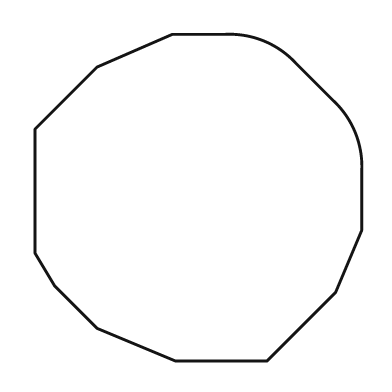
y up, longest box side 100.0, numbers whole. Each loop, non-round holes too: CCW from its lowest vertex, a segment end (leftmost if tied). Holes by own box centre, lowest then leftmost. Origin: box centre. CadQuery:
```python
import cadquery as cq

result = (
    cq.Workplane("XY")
    .moveTo(-7.0, -50.0)
    .lineTo(21.0, -50.0)
    .lineTo(42.0, -29.0)
    .lineTo(50.0, -10.0)
    .lineTo(50.0, 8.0)
    .threePointArc((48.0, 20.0), (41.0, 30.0))
    .lineTo(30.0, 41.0)
    .threePointArc((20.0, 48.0), (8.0, 50.0))
    .lineTo(-8.0, 50.0)
    .lineTo(-31.0, 40.0)
    .lineTo(-50.0, 21.0)
    .lineTo(-50.0, -17.0)
    .lineTo(-44.0, -27.0)
    .lineTo(-31.0, -40.0)
    .close()
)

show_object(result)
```